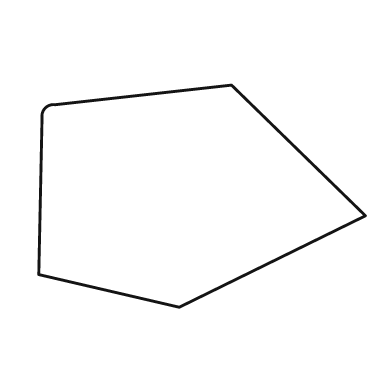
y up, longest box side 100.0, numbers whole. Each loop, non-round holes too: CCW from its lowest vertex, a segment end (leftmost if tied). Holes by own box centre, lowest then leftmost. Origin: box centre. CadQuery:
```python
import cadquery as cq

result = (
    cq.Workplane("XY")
    .moveTo(-7.0, -34.0)
    .lineTo(50.0, -6.0)
    .lineTo(9.0, 34.0)
    .lineTo(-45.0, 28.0)
    .threePointArc((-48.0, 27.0), (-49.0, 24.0))
    .lineTo(-50.0, -24.0)
    .close()
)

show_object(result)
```